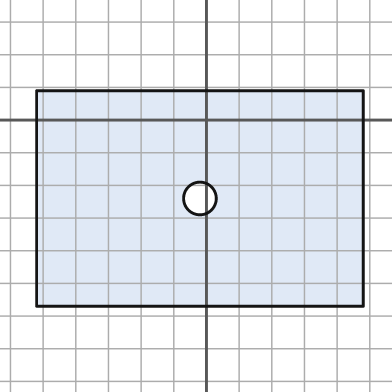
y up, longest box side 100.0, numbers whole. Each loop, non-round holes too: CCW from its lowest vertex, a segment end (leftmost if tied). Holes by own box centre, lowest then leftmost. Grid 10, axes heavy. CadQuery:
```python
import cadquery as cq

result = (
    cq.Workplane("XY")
    .moveTo(-52.0, -57.0)
    .lineTo(48.0, -57.0)
    .lineTo(48.0, 9.0)
    .lineTo(-52.0, 9.0)
    .close()
    .moveTo(-2.0, -24.0)
    .circle(5.0)
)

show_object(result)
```